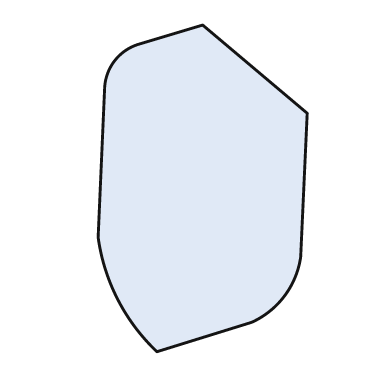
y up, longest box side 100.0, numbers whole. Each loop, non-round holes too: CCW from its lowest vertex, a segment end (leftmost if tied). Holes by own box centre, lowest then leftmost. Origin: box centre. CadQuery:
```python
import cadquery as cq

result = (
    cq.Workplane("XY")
    .moveTo(-14.0, -50.0)
    .lineTo(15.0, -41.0)
    .threePointArc((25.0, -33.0), (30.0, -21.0))
    .lineTo(32.0, 23.0)
    .lineTo(0.0, 50.0)
    .lineTo(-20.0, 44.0)
    .threePointArc((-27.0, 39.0), (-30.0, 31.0))
    .lineTo(-32.0, -15.0)
    .threePointArc((-26.0, -34.0), (-14.0, -50.0))
    .close()
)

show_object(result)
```